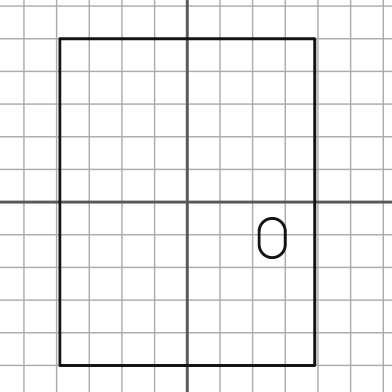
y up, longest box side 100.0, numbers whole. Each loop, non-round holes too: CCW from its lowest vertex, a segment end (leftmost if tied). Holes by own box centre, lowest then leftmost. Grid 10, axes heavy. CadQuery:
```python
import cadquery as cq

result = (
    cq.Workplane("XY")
    .moveTo(-39.0, -50.0)
    .lineTo(39.0, -50.0)
    .lineTo(39.0, 50.0)
    .lineTo(-39.0, 50.0)
    .close()
    .moveTo(22.0, -13.0)
    .threePointArc((26.0, -17.0), (30.0, -13.0))
    .lineTo(30.0, -9.0)
    .threePointArc((26.0, -5.0), (22.0, -9.0))
    .close()
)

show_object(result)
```